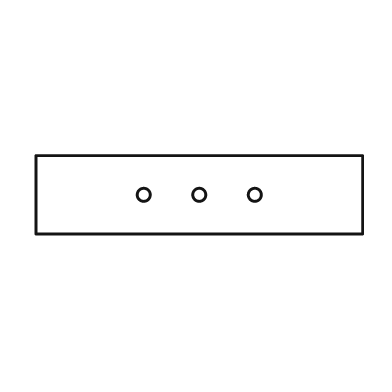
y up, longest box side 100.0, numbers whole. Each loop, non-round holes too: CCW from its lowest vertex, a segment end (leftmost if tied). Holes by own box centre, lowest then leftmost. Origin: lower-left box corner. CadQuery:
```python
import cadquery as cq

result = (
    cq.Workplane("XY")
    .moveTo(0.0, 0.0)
    .lineTo(100.0, 0.0)
    .lineTo(100.0, 24.0)
    .lineTo(0.0, 24.0)
    .close()
    .moveTo(33.0, 12.0)
    .circle(2.0)
    .moveTo(50.0, 12.0)
    .circle(2.0)
    .moveTo(67.0, 12.0)
    .circle(2.0)
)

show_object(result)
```